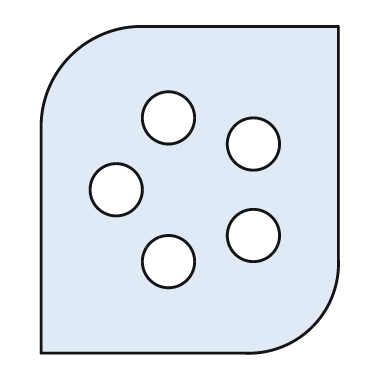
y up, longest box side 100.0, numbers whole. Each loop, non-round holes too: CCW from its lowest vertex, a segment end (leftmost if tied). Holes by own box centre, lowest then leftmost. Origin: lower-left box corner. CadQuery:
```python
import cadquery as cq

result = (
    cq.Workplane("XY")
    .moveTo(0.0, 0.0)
    .lineTo(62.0, 0.0)
    .threePointArc((83.0, 8.0), (91.0, 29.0))
    .lineTo(91.0, 100.0)
    .lineTo(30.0, 100.0)
    .threePointArc((9.0, 91.0), (0.0, 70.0))
    .close()
    .moveTo(39.0, 28.0)
    .circle(8.0)
    .moveTo(65.0, 36.0)
    .circle(8.0)
    .moveTo(23.0, 50.0)
    .circle(8.0)
    .moveTo(65.0, 64.0)
    .circle(8.0)
    .moveTo(39.0, 72.0)
    .circle(8.0)
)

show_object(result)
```